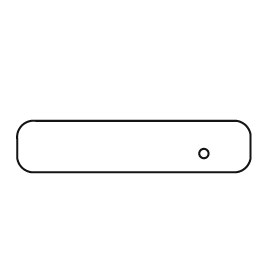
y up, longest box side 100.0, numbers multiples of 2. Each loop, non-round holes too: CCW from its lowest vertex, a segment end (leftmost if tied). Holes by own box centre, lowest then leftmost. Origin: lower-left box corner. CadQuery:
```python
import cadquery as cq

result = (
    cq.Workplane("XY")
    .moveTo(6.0, 0.0)
    .lineTo(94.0, 0.0)
    .threePointArc((98.0, 2.0), (100.0, 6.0))
    .lineTo(100.0, 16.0)
    .threePointArc((98.0, 20.0), (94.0, 22.0))
    .lineTo(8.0, 22.0)
    .threePointArc((2.0, 20.0), (0.0, 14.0))
    .lineTo(0.0, 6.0)
    .threePointArc((2.0, 2.0), (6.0, 0.0))
    .close()
    .moveTo(80.0, 8.0)
    .circle(2.0)
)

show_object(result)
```